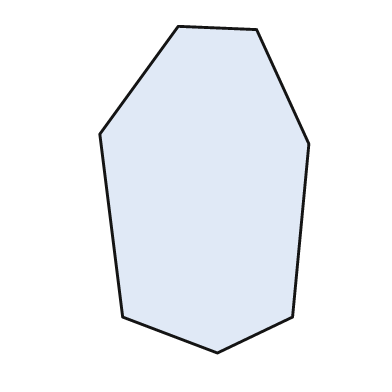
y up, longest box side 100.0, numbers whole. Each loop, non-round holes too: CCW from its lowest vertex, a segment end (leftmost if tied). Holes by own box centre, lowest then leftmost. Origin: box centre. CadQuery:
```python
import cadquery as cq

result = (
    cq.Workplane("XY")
    .moveTo(4.0, -50.0)
    .lineTo(27.0, -39.0)
    .lineTo(32.0, 14.0)
    .lineTo(16.0, 49.0)
    .lineTo(-8.0, 50.0)
    .lineTo(-32.0, 17.0)
    .lineTo(-25.0, -39.0)
    .close()
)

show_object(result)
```